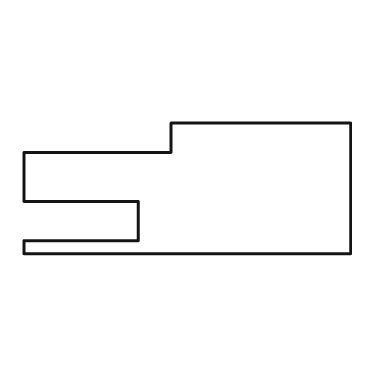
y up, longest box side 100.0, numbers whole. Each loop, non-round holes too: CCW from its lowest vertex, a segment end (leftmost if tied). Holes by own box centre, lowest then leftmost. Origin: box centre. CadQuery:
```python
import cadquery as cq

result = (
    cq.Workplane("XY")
    .moveTo(-50.0, -20.0)
    .lineTo(50.0, -20.0)
    .lineTo(50.0, 20.0)
    .lineTo(-5.0, 20.0)
    .lineTo(-5.0, 11.0)
    .lineTo(-50.0, 11.0)
    .lineTo(-50.0, -4.0)
    .lineTo(-15.0, -4.0)
    .lineTo(-15.0, -16.0)
    .lineTo(-50.0, -16.0)
    .close()
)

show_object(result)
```